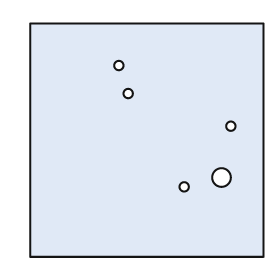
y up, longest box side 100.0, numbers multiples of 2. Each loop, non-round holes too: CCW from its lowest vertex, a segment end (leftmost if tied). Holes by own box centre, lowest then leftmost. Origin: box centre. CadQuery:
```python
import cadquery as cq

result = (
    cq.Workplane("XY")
    .moveTo(-50.0, -50.0)
    .lineTo(50.0, -50.0)
    .lineTo(50.0, 50.0)
    .lineTo(-50.0, 50.0)
    .close()
    .moveTo(16.0, -20.0)
    .circle(2.0)
    .moveTo(32.0, -16.0)
    .circle(4.0)
    .moveTo(36.0, 6.0)
    .circle(2.0)
    .moveTo(-8.0, 20.0)
    .circle(2.0)
    .moveTo(-12.0, 32.0)
    .circle(2.0)
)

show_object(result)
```